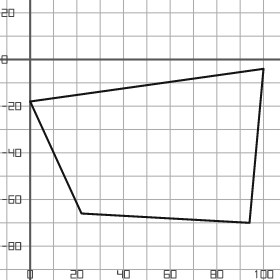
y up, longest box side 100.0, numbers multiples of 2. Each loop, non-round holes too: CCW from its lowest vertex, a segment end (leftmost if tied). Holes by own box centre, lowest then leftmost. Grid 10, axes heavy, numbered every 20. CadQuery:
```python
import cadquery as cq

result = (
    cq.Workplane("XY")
    .moveTo(94.0, -70.0)
    .lineTo(100.0, -4.0)
    .lineTo(0.0, -18.0)
    .lineTo(22.0, -66.0)
    .close()
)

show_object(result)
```